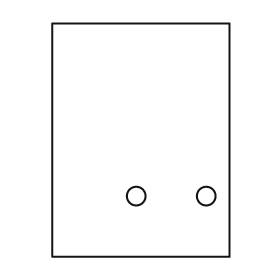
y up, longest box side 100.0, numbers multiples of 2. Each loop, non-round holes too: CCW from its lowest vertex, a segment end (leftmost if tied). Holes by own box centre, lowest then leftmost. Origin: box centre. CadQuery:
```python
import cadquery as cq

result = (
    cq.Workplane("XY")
    .moveTo(-38.0, -50.0)
    .lineTo(38.0, -50.0)
    .lineTo(38.0, 50.0)
    .lineTo(-38.0, 50.0)
    .close()
    .moveTo(-2.0, -24.0)
    .circle(4.0)
    .moveTo(28.0, -24.0)
    .circle(4.0)
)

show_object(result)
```